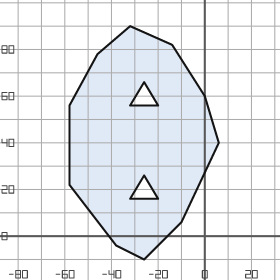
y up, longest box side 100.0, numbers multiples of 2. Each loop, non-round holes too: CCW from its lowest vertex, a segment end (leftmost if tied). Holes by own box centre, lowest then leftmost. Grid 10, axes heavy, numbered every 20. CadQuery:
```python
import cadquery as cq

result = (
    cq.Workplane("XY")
    .moveTo(-26.0, -10.0)
    .lineTo(-10.0, 6.0)
    .lineTo(6.0, 40.0)
    .lineTo(0.0, 60.0)
    .lineTo(-14.0, 82.0)
    .lineTo(-32.0, 90.0)
    .lineTo(-46.0, 78.0)
    .lineTo(-58.0, 56.0)
    .lineTo(-58.0, 22.0)
    .lineTo(-38.0, -4.0)
    .close()
    .moveTo(-32.0, 16.0)
    .lineTo(-20.0, 16.0)
    .lineTo(-26.0, 26.0)
    .close()
    .moveTo(-32.0, 56.0)
    .lineTo(-20.0, 56.0)
    .lineTo(-26.0, 66.0)
    .close()
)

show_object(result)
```